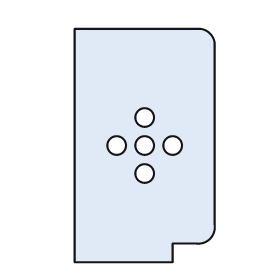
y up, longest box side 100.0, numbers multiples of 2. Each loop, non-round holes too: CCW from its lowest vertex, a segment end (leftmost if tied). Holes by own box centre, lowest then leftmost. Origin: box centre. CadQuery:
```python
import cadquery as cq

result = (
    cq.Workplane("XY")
    .moveTo(-30.0, -50.0)
    .lineTo(12.0, -50.0)
    .lineTo(12.0, -42.0)
    .lineTo(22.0, -42.0)
    .threePointArc((28.0, -40.0), (30.0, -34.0))
    .lineTo(30.0, 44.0)
    .threePointArc((28.0, 48.0), (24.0, 50.0))
    .lineTo(-30.0, 50.0)
    .close()
    .moveTo(0.0, -12.0)
    .circle(4.0)
    .moveTo(-12.0, 0.0)
    .circle(4.0)
    .moveTo(0.0, 0.0)
    .circle(4.0)
    .moveTo(12.0, 0.0)
    .circle(4.0)
    .moveTo(0.0, 12.0)
    .circle(4.0)
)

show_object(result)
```